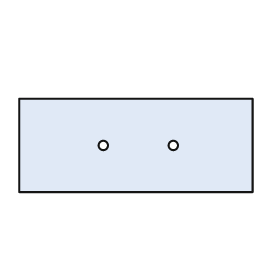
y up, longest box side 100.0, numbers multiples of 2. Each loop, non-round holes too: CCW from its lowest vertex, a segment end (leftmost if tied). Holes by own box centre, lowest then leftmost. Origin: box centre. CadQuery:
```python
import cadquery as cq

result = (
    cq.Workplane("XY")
    .moveTo(-50.0, -20.0)
    .lineTo(50.0, -20.0)
    .lineTo(50.0, 20.0)
    .lineTo(-50.0, 20.0)
    .close()
    .moveTo(-14.0, 0.0)
    .circle(2.0)
    .moveTo(16.0, 0.0)
    .circle(2.0)
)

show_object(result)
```